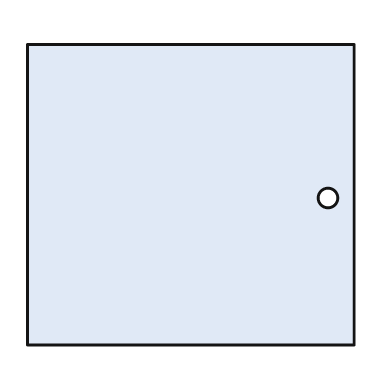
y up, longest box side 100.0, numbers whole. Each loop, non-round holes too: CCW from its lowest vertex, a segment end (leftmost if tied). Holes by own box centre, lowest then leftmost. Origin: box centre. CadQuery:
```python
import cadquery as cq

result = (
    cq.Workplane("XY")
    .moveTo(-50.0, -46.0)
    .lineTo(50.0, -46.0)
    .lineTo(50.0, 46.0)
    .lineTo(-50.0, 46.0)
    .close()
    .moveTo(42.0, -1.0)
    .circle(3.0)
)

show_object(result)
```